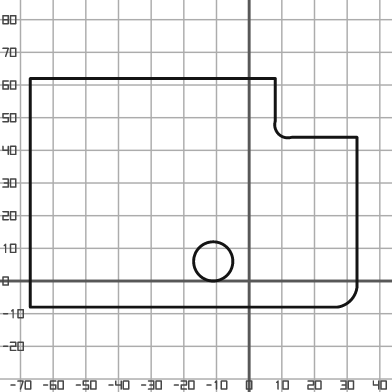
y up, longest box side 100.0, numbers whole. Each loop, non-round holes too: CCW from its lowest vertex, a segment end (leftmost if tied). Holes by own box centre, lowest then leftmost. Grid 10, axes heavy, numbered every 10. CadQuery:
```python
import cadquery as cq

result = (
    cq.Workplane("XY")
    .moveTo(-67.0, -8.0)
    .lineTo(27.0, -8.0)
    .threePointArc((31.0, -6.0), (33.0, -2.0))
    .lineTo(33.0, 44.0)
    .lineTo(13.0, 44.0)
    .threePointArc((9.0, 45.0), (8.0, 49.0))
    .lineTo(8.0, 62.0)
    .lineTo(-67.0, 62.0)
    .close()
    .moveTo(-11.0, 6.0)
    .circle(6.0)
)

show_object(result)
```